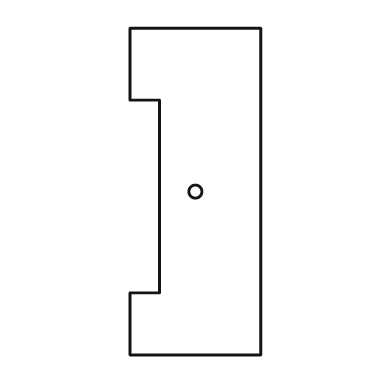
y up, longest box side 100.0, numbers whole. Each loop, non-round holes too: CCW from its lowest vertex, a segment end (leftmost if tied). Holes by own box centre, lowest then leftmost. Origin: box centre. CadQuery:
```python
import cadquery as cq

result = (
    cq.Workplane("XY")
    .moveTo(-20.0, -50.0)
    .lineTo(20.0, -50.0)
    .lineTo(20.0, 50.0)
    .lineTo(-20.0, 50.0)
    .lineTo(-20.0, 28.0)
    .lineTo(-11.0, 28.0)
    .lineTo(-11.0, -31.0)
    .lineTo(-20.0, -31.0)
    .close()
    .moveTo(0.0, 0.0)
    .circle(2.0)
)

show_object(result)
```